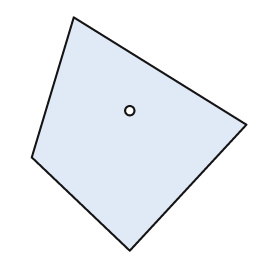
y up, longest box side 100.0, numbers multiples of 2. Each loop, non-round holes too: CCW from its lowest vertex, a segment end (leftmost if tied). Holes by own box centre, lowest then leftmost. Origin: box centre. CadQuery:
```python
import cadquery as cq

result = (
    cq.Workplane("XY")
    .moveTo(-4.0, -50.0)
    .lineTo(46.0, 4.0)
    .lineTo(-28.0, 50.0)
    .lineTo(-46.0, -10.0)
    .close()
    .moveTo(-4.0, 10.0)
    .circle(2.0)
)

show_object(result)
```